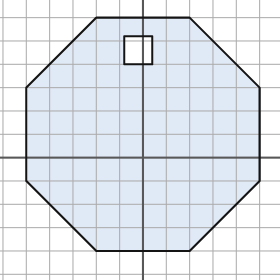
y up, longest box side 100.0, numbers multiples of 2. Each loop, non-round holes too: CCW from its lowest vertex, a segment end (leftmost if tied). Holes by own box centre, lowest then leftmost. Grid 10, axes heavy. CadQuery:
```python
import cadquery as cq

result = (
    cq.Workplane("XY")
    .moveTo(-20.0, -40.0)
    .lineTo(20.0, -40.0)
    .lineTo(50.0, -10.0)
    .lineTo(50.0, 30.0)
    .lineTo(20.0, 60.0)
    .lineTo(-20.0, 60.0)
    .lineTo(-50.0, 30.0)
    .lineTo(-50.0, -10.0)
    .close()
    .moveTo(-8.0, 40.0)
    .lineTo(4.0, 40.0)
    .lineTo(4.0, 52.0)
    .lineTo(-8.0, 52.0)
    .close()
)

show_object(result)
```